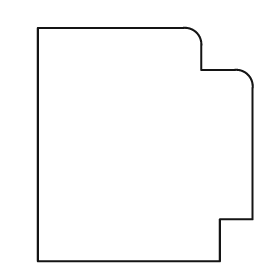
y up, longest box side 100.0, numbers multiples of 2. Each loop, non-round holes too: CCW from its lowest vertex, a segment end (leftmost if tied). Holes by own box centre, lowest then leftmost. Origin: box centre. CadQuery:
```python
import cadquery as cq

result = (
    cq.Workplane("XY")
    .moveTo(-46.0, -50.0)
    .lineTo(32.0, -50.0)
    .lineTo(32.0, -32.0)
    .lineTo(46.0, -32.0)
    .lineTo(46.0, 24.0)
    .threePointArc((44.0, 30.0), (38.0, 32.0))
    .lineTo(24.0, 32.0)
    .lineTo(24.0, 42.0)
    .threePointArc((22.0, 48.0), (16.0, 50.0))
    .lineTo(-46.0, 50.0)
    .close()
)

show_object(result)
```